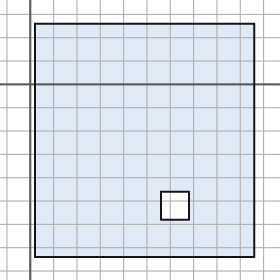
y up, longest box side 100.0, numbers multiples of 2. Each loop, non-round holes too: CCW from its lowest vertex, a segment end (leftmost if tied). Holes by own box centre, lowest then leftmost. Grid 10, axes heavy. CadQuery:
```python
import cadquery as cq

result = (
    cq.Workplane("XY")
    .moveTo(2.0, -74.0)
    .lineTo(96.0, -74.0)
    .lineTo(96.0, 26.0)
    .lineTo(2.0, 26.0)
    .close()
    .moveTo(56.0, -58.0)
    .lineTo(68.0, -58.0)
    .lineTo(68.0, -46.0)
    .lineTo(56.0, -46.0)
    .close()
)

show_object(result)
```